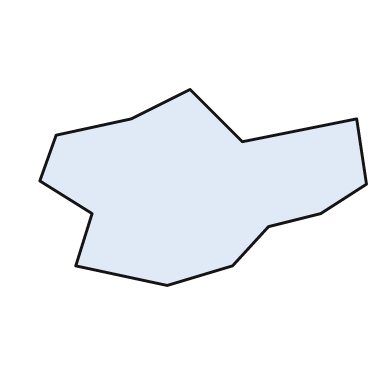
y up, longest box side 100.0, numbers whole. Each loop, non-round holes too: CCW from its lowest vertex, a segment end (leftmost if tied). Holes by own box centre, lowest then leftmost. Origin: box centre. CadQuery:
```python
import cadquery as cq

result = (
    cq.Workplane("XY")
    .moveTo(-11.0, -30.0)
    .lineTo(9.0, -24.0)
    .lineTo(20.0, -12.0)
    .lineTo(36.0, -8.0)
    .lineTo(50.0, 1.0)
    .lineTo(47.0, 21.0)
    .lineTo(12.0, 14.0)
    .lineTo(-4.0, 30.0)
    .lineTo(-22.0, 21.0)
    .lineTo(-45.0, 16.0)
    .lineTo(-50.0, 2.0)
    .lineTo(-34.0, -8.0)
    .lineTo(-39.0, -24.0)
    .close()
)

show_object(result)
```